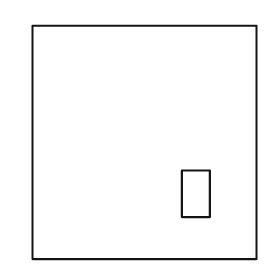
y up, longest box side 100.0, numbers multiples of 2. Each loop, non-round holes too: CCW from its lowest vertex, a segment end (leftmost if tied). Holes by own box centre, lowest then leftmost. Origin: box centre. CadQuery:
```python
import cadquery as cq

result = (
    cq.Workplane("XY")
    .moveTo(-48.0, -50.0)
    .lineTo(48.0, -50.0)
    .lineTo(48.0, 50.0)
    .lineTo(-48.0, 50.0)
    .close()
    .moveTo(16.0, -32.0)
    .lineTo(28.0, -32.0)
    .lineTo(28.0, -12.0)
    .lineTo(16.0, -12.0)
    .close()
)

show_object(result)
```